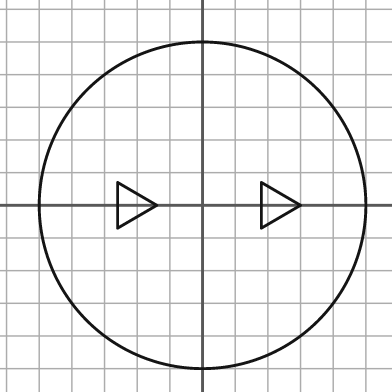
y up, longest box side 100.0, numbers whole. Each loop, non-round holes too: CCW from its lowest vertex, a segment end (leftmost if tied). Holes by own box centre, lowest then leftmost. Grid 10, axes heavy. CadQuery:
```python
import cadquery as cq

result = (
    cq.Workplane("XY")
    .moveTo(0.0, 0.0)
    .circle(50.0)
    .moveTo(-26.0, -7.0)
    .lineTo(-14.0, 0.0)
    .lineTo(-26.0, 7.0)
    .close()
    .moveTo(18.0, -7.0)
    .lineTo(30.0, 0.0)
    .lineTo(18.0, 7.0)
    .close()
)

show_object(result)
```